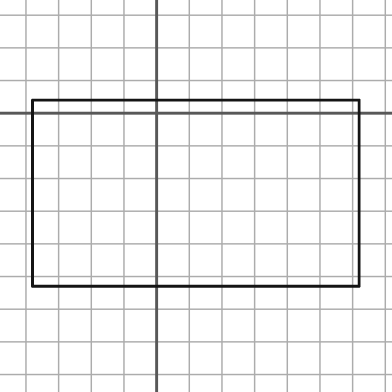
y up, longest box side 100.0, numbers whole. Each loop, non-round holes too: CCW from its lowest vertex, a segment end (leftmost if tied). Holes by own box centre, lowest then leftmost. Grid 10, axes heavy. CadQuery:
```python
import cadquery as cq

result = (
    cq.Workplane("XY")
    .moveTo(-38.0, -53.0)
    .lineTo(62.0, -53.0)
    .lineTo(62.0, 4.0)
    .lineTo(-38.0, 4.0)
    .close()
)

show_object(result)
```